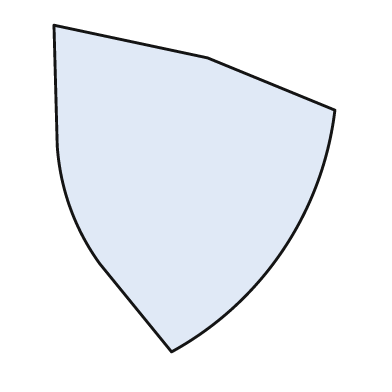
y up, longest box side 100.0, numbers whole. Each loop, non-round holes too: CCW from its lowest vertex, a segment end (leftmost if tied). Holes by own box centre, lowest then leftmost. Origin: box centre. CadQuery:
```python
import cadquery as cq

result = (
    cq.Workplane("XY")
    .moveTo(-7.0, -50.0)
    .threePointArc((27.0, -19.0), (43.0, 24.0))
    .lineTo(4.0, 40.0)
    .lineTo(-43.0, 50.0)
    .lineTo(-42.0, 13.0)
    .threePointArc((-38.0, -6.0), (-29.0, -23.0))
    .close()
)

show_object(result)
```